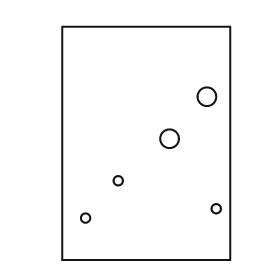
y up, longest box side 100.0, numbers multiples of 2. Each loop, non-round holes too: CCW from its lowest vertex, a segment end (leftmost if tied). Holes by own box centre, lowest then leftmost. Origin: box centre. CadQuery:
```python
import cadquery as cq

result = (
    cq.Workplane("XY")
    .moveTo(-36.0, -50.0)
    .lineTo(36.0, -50.0)
    .lineTo(36.0, 50.0)
    .lineTo(-36.0, 50.0)
    .close()
    .moveTo(-26.0, -32.0)
    .circle(2.0)
    .moveTo(30.0, -28.0)
    .circle(2.0)
    .moveTo(-12.0, -16.0)
    .circle(2.0)
    .moveTo(10.0, 2.0)
    .circle(4.0)
    .moveTo(26.0, 20.0)
    .circle(4.0)
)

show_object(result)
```